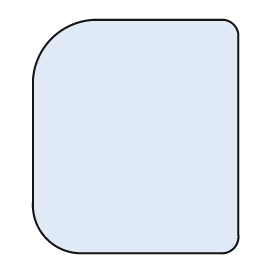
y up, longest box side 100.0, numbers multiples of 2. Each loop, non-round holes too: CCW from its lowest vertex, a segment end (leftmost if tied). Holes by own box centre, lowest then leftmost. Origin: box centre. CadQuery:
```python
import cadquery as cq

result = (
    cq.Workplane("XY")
    .moveTo(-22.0, -50.0)
    .lineTo(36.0, -50.0)
    .threePointArc((42.0, -48.0), (44.0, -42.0))
    .lineTo(44.0, 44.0)
    .threePointArc((42.0, 48.0), (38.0, 50.0))
    .lineTo(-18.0, 50.0)
    .threePointArc((-36.0, 42.0), (-44.0, 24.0))
    .lineTo(-44.0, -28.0)
    .threePointArc((-38.0, -44.0), (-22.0, -50.0))
    .close()
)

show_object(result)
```